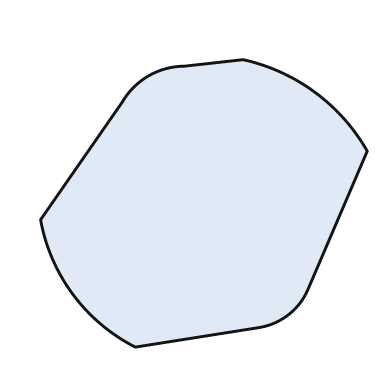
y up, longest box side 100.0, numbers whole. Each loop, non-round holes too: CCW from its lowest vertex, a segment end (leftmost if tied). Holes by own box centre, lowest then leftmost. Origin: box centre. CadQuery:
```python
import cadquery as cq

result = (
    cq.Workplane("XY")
    .moveTo(-21.0, -44.0)
    .lineTo(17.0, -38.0)
    .threePointArc((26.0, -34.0), (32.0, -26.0))
    .lineTo(50.0, 16.0)
    .threePointArc((34.0, 34.0), (12.0, 44.0))
    .lineTo(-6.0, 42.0)
    .threePointArc((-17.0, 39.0), (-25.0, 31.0))
    .lineTo(-50.0, -5.0)
    .threePointArc((-40.0, -28.0), (-21.0, -44.0))
    .close()
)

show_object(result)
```